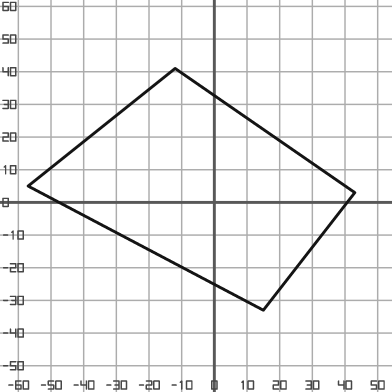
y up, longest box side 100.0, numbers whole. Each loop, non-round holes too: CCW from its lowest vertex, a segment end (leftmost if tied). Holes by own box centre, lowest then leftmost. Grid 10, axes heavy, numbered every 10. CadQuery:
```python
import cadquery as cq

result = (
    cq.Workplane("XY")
    .moveTo(15.0, -33.0)
    .lineTo(43.0, 3.0)
    .lineTo(-12.0, 41.0)
    .lineTo(-57.0, 5.0)
    .close()
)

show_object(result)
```